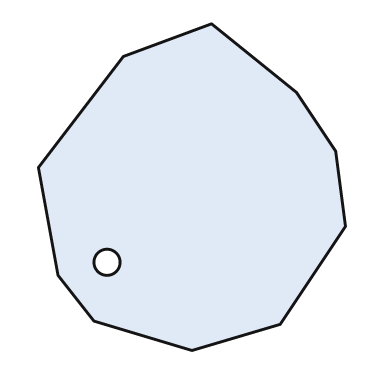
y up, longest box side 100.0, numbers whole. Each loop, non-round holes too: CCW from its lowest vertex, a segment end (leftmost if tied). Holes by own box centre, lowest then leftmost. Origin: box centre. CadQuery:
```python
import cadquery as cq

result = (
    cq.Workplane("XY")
    .moveTo(0.0, -50.0)
    .lineTo(27.0, -42.0)
    .lineTo(47.0, -12.0)
    .lineTo(44.0, 11.0)
    .lineTo(32.0, 29.0)
    .lineTo(6.0, 50.0)
    .lineTo(-21.0, 40.0)
    .lineTo(-47.0, 6.0)
    .lineTo(-41.0, -27.0)
    .lineTo(-30.0, -41.0)
    .close()
    .moveTo(-26.0, -23.0)
    .circle(4.0)
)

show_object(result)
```